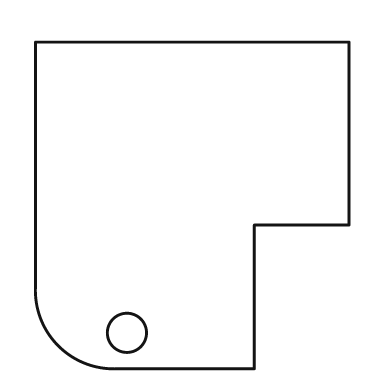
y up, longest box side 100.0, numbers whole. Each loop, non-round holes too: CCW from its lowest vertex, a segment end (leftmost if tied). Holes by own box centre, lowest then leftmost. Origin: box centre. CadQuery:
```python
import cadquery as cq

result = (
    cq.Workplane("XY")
    .moveTo(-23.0, -50.0)
    .lineTo(19.0, -50.0)
    .lineTo(19.0, -6.0)
    .lineTo(48.0, -6.0)
    .lineTo(48.0, 50.0)
    .lineTo(-48.0, 50.0)
    .lineTo(-48.0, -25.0)
    .threePointArc((-41.0, -43.0), (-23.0, -50.0))
    .close()
    .moveTo(-20.0, -39.0)
    .circle(6.0)
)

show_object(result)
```